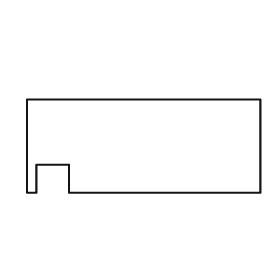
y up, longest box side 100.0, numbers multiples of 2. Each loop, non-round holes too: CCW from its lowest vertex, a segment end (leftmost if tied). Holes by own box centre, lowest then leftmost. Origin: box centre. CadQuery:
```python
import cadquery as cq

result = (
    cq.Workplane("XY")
    .moveTo(-50.0, -20.0)
    .lineTo(-46.0, -20.0)
    .lineTo(-46.0, -8.0)
    .lineTo(-32.0, -8.0)
    .lineTo(-32.0, -20.0)
    .lineTo(50.0, -20.0)
    .lineTo(50.0, 20.0)
    .lineTo(-50.0, 20.0)
    .close()
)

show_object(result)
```